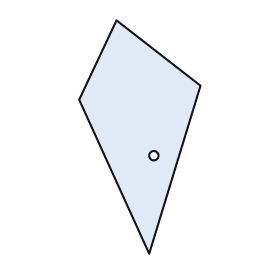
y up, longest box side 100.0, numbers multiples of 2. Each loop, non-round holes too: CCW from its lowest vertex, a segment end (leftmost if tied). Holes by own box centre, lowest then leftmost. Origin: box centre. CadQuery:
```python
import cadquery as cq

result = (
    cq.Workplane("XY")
    .moveTo(4.0, -50.0)
    .lineTo(26.0, 22.0)
    .lineTo(-10.0, 50.0)
    .lineTo(-26.0, 16.0)
    .close()
    .moveTo(6.0, -8.0)
    .circle(2.0)
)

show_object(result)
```